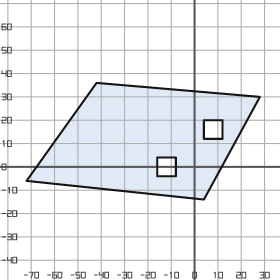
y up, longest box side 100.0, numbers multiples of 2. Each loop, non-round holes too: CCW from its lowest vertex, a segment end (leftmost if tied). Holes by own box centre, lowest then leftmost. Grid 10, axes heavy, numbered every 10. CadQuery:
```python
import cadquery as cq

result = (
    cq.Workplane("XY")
    .moveTo(4.0, -14.0)
    .lineTo(28.0, 30.0)
    .lineTo(-42.0, 36.0)
    .lineTo(-72.0, -6.0)
    .close()
    .moveTo(-16.0, -4.0)
    .lineTo(-8.0, -4.0)
    .lineTo(-8.0, 4.0)
    .lineTo(-16.0, 4.0)
    .close()
    .moveTo(4.0, 12.0)
    .lineTo(12.0, 12.0)
    .lineTo(12.0, 20.0)
    .lineTo(4.0, 20.0)
    .close()
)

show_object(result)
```